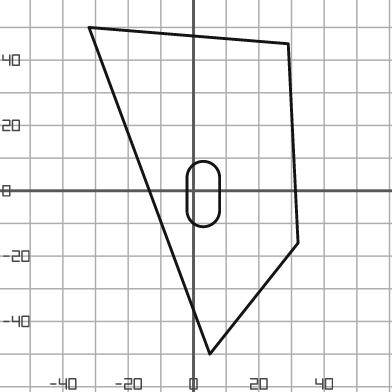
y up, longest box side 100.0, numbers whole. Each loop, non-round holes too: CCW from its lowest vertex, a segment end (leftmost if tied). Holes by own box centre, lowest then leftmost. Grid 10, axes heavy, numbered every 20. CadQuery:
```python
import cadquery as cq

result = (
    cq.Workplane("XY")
    .moveTo(5.0, -50.0)
    .lineTo(32.0, -16.0)
    .lineTo(29.0, 45.0)
    .lineTo(-32.0, 50.0)
    .close()
    .moveTo(-2.0, -6.0)
    .threePointArc((3.0, -11.0), (8.0, -6.0))
    .lineTo(8.0, 4.0)
    .threePointArc((3.0, 9.0), (-2.0, 4.0))
    .close()
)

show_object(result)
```